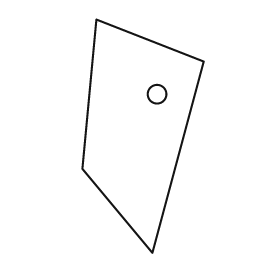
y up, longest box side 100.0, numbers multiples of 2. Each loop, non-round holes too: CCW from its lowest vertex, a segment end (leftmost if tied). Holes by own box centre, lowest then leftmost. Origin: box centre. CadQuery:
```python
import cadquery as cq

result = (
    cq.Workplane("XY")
    .moveTo(4.0, -50.0)
    .lineTo(26.0, 32.0)
    .lineTo(-20.0, 50.0)
    .lineTo(-26.0, -14.0)
    .close()
    .moveTo(6.0, 18.0)
    .circle(4.0)
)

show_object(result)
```